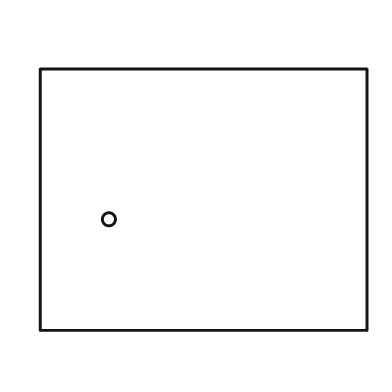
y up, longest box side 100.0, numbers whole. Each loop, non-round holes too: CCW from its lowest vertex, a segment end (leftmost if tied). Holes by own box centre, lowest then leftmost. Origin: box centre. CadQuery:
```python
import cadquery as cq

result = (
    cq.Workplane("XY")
    .moveTo(-50.0, -40.0)
    .lineTo(50.0, -40.0)
    .lineTo(50.0, 40.0)
    .lineTo(-50.0, 40.0)
    .close()
    .moveTo(-29.0, -6.0)
    .circle(2.0)
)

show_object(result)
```